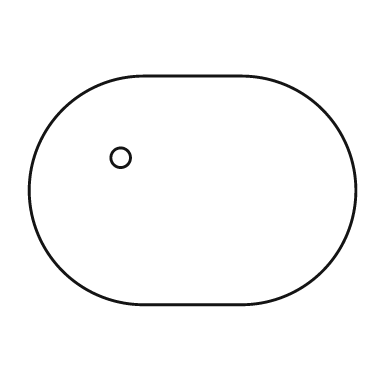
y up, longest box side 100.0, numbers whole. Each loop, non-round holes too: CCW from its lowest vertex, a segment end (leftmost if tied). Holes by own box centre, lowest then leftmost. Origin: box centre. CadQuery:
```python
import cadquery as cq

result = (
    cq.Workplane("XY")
    .moveTo(-15.0, -35.0)
    .lineTo(15.0, -35.0)
    .threePointArc((50.0, 0.0), (15.0, 35.0))
    .lineTo(-15.0, 35.0)
    .threePointArc((-50.0, 0.0), (-15.0, -35.0))
    .close()
    .moveTo(-22.0, 10.0)
    .circle(3.0)
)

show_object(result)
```